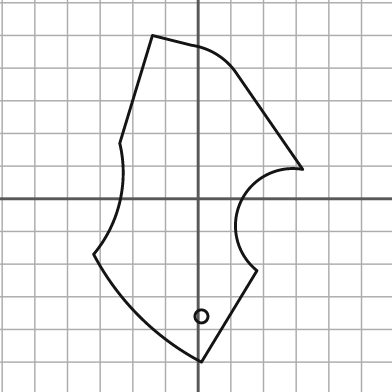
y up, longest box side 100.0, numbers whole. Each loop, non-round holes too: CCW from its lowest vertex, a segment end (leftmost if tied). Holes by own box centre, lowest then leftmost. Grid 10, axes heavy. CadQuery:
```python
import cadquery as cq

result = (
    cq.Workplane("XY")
    .moveTo(1.0, -50.0)
    .lineTo(18.0, -22.0)
    .threePointArc((13.0, -1.0), (32.0, 9.0))
    .lineTo(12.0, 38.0)
    .threePointArc((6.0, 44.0), (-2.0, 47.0))
    .lineTo(-14.0, 50.0)
    .lineTo(-24.0, 17.0)
    .threePointArc((-24.0, -1.0), (-32.0, -17.0))
    .threePointArc((-18.0, -36.0), (1.0, -50.0))
    .close()
    .moveTo(1.0, -36.0)
    .circle(2.0)
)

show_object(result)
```